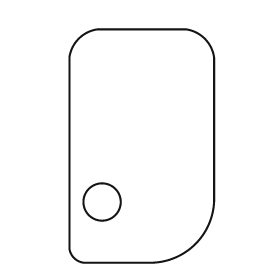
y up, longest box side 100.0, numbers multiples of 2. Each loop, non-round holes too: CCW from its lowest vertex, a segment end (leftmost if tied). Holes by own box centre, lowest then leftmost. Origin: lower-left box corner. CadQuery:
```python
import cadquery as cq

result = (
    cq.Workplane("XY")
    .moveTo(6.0, 0.0)
    .lineTo(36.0, 0.0)
    .threePointArc((54.0, 8.0), (62.0, 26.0))
    .lineTo(62.0, 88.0)
    .threePointArc((58.0, 96.0), (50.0, 100.0))
    .lineTo(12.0, 100.0)
    .threePointArc((4.0, 96.0), (0.0, 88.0))
    .lineTo(0.0, 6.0)
    .threePointArc((2.0, 2.0), (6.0, 0.0))
    .close()
    .moveTo(14.0, 26.0)
    .circle(8.0)
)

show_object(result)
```